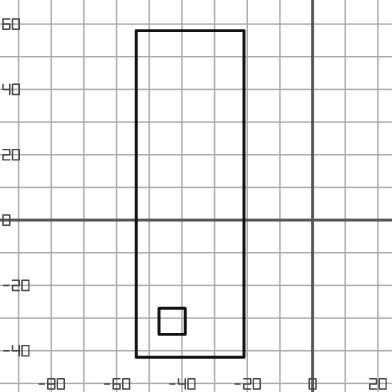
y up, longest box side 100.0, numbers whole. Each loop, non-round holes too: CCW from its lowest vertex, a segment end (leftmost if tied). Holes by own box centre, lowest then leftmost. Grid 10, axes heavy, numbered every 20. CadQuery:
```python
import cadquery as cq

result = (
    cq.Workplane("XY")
    .moveTo(-54.0, -42.0)
    .lineTo(-21.0, -42.0)
    .lineTo(-21.0, 58.0)
    .lineTo(-54.0, 58.0)
    .close()
    .moveTo(-47.0, -35.0)
    .lineTo(-39.0, -35.0)
    .lineTo(-39.0, -27.0)
    .lineTo(-47.0, -27.0)
    .close()
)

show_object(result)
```